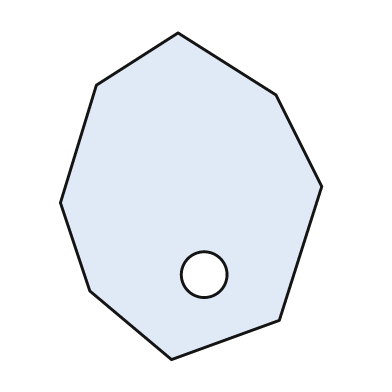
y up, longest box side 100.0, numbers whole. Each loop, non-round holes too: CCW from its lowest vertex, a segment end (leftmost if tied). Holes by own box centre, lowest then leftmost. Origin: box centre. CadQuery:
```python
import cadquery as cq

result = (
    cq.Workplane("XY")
    .moveTo(-6.0, -50.0)
    .lineTo(27.0, -38.0)
    .lineTo(40.0, 3.0)
    .lineTo(26.0, 31.0)
    .lineTo(-4.0, 50.0)
    .lineTo(-29.0, 34.0)
    .lineTo(-40.0, -2.0)
    .lineTo(-31.0, -29.0)
    .close()
    .moveTo(4.0, -24.0)
    .circle(7.0)
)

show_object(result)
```